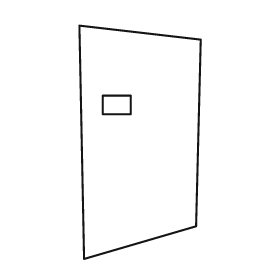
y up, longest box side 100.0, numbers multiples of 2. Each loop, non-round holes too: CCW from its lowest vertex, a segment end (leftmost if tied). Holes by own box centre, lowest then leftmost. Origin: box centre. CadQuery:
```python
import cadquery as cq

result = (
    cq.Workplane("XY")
    .moveTo(-24.0, -50.0)
    .lineTo(24.0, -36.0)
    .lineTo(26.0, 44.0)
    .lineTo(-26.0, 50.0)
    .close()
    .moveTo(-16.0, 12.0)
    .lineTo(-4.0, 12.0)
    .lineTo(-4.0, 20.0)
    .lineTo(-16.0, 20.0)
    .close()
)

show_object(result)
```